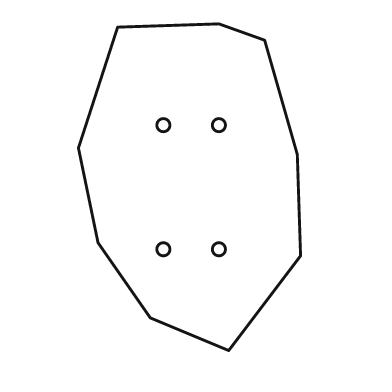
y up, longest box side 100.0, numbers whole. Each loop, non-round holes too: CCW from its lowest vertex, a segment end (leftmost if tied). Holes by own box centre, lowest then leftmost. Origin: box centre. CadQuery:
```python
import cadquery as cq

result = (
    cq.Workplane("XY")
    .moveTo(12.0, -50.0)
    .lineTo(34.0, -21.0)
    .lineTo(33.0, 10.0)
    .lineTo(23.0, 45.0)
    .lineTo(9.0, 50.0)
    .lineTo(-22.0, 49.0)
    .lineTo(-34.0, 12.0)
    .lineTo(-28.0, -17.0)
    .lineTo(-12.0, -40.0)
    .close()
    .moveTo(-8.0, -19.0)
    .circle(2.0)
    .moveTo(9.0, -19.0)
    .circle(2.0)
    .moveTo(-8.0, 19.0)
    .circle(2.0)
    .moveTo(9.0, 19.0)
    .circle(2.0)
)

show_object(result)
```